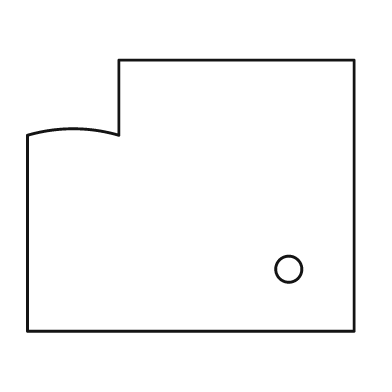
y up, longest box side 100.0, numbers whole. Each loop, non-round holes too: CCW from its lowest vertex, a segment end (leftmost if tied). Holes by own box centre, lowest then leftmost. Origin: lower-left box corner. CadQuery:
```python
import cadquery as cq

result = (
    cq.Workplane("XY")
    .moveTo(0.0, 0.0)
    .lineTo(100.0, 0.0)
    .lineTo(100.0, 83.0)
    .lineTo(28.0, 83.0)
    .lineTo(28.0, 60.0)
    .threePointArc((14.0, 62.0), (0.0, 60.0))
    .close()
    .moveTo(80.0, 19.0)
    .circle(4.0)
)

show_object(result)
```